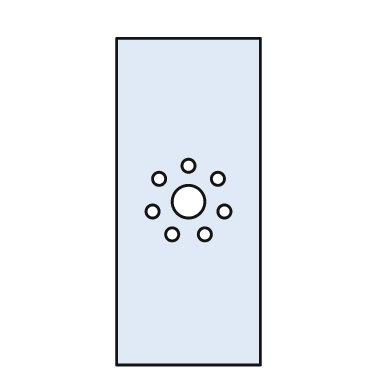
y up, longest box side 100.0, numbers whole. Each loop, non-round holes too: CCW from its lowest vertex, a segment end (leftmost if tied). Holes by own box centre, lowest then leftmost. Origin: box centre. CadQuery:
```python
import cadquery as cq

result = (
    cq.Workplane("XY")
    .moveTo(-22.0, -50.0)
    .lineTo(22.0, -50.0)
    .lineTo(22.0, 50.0)
    .lineTo(-22.0, 50.0)
    .close()
    .moveTo(-5.0, -10.0)
    .circle(2.0)
    .moveTo(5.0, -10.0)
    .circle(2.0)
    .moveTo(-11.0, -3.0)
    .circle(2.0)
    .moveTo(11.0, -3.0)
    .circle(2.0)
    .moveTo(0.0, 0.0)
    .circle(5.0)
    .moveTo(-9.0, 7.0)
    .circle(2.0)
    .moveTo(9.0, 7.0)
    .circle(2.0)
    .moveTo(0.0, 11.0)
    .circle(2.0)
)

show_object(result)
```